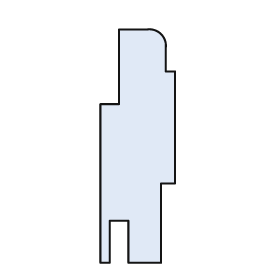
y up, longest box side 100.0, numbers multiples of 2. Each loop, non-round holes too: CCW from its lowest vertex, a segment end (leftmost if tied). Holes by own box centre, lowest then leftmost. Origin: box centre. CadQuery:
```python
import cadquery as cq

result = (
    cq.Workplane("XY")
    .moveTo(-16.0, -50.0)
    .lineTo(-12.0, -50.0)
    .lineTo(-12.0, -32.0)
    .lineTo(-4.0, -32.0)
    .lineTo(-4.0, -50.0)
    .lineTo(10.0, -50.0)
    .lineTo(10.0, -16.0)
    .lineTo(16.0, -16.0)
    .lineTo(16.0, 32.0)
    .lineTo(12.0, 32.0)
    .lineTo(12.0, 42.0)
    .threePointArc((10.0, 48.0), (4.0, 50.0))
    .lineTo(-8.0, 50.0)
    .lineTo(-8.0, 18.0)
    .lineTo(-16.0, 18.0)
    .close()
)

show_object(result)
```